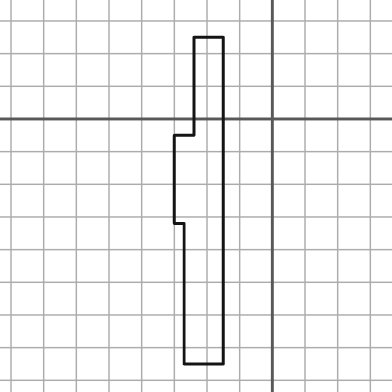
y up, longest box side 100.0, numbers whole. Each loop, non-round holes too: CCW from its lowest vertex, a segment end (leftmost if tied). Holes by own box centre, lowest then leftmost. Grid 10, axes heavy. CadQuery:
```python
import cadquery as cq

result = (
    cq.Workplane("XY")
    .moveTo(-27.0, -75.0)
    .lineTo(-15.0, -75.0)
    .lineTo(-15.0, 25.0)
    .lineTo(-24.0, 25.0)
    .lineTo(-24.0, -5.0)
    .lineTo(-30.0, -5.0)
    .lineTo(-30.0, -32.0)
    .lineTo(-27.0, -32.0)
    .close()
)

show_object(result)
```